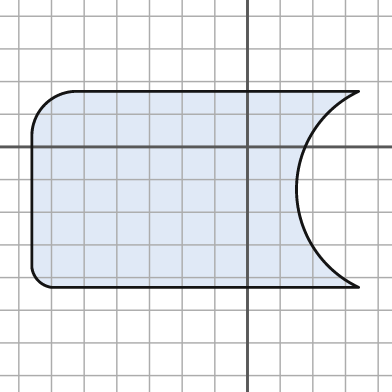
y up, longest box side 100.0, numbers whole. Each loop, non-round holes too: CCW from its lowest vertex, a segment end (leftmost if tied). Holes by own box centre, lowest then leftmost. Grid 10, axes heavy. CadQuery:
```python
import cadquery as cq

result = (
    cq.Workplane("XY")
    .moveTo(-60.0, -43.0)
    .lineTo(34.0, -43.0)
    .threePointArc((15.0, -13.0), (34.0, 17.0))
    .lineTo(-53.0, 17.0)
    .threePointArc((-62.0, 13.0), (-66.0, 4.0))
    .lineTo(-66.0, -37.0)
    .threePointArc((-64.0, -41.0), (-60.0, -43.0))
    .close()
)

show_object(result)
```